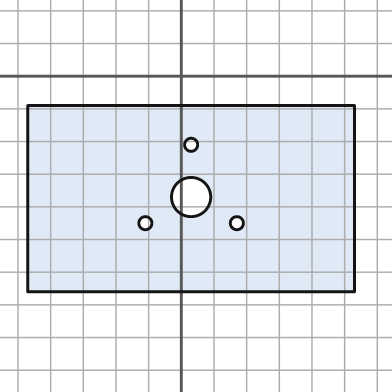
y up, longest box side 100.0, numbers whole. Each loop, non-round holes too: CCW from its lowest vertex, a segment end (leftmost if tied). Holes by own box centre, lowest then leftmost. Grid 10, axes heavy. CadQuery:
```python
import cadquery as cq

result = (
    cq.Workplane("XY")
    .moveTo(-47.0, -66.0)
    .lineTo(53.0, -66.0)
    .lineTo(53.0, -9.0)
    .lineTo(-47.0, -9.0)
    .close()
    .moveTo(-11.0, -45.0)
    .circle(2.0)
    .moveTo(17.0, -45.0)
    .circle(2.0)
    .moveTo(3.0, -37.0)
    .circle(6.0)
    .moveTo(3.0, -21.0)
    .circle(2.0)
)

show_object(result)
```